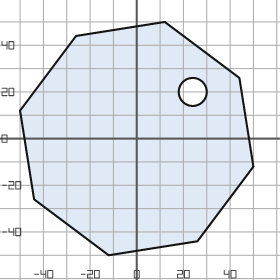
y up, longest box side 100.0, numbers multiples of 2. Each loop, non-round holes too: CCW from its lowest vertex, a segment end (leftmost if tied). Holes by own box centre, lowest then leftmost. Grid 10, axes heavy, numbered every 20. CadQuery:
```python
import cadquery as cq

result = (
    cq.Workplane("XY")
    .moveTo(-12.0, -50.0)
    .lineTo(26.0, -44.0)
    .lineTo(50.0, -12.0)
    .lineTo(44.0, 26.0)
    .lineTo(12.0, 50.0)
    .lineTo(-26.0, 44.0)
    .lineTo(-50.0, 12.0)
    .lineTo(-44.0, -26.0)
    .close()
    .moveTo(24.0, 20.0)
    .circle(6.0)
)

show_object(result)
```